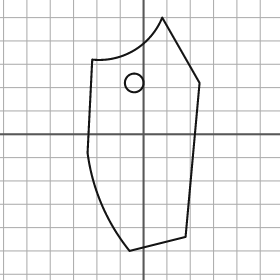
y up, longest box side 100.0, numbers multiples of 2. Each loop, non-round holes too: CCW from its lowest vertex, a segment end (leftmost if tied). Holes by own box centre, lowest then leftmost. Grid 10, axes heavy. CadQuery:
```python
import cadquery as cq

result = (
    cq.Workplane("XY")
    .moveTo(-6.0, -50.0)
    .lineTo(18.0, -44.0)
    .lineTo(24.0, 22.0)
    .lineTo(8.0, 50.0)
    .threePointArc((-4.0, 36.0), (-22.0, 32.0))
    .lineTo(-24.0, -8.0)
    .threePointArc((-18.0, -30.0), (-6.0, -50.0))
    .close()
    .moveTo(-4.0, 22.0)
    .circle(4.0)
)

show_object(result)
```